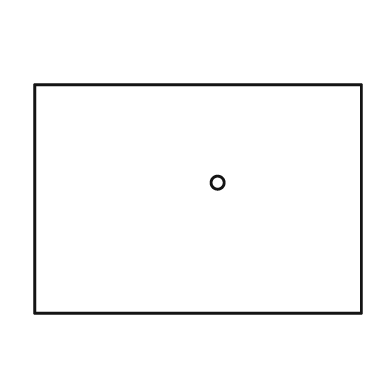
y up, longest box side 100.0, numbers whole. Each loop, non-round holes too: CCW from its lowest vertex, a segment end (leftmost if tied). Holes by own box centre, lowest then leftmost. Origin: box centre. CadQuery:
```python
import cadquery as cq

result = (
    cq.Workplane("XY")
    .moveTo(-50.0, -35.0)
    .lineTo(50.0, -35.0)
    .lineTo(50.0, 35.0)
    .lineTo(-50.0, 35.0)
    .close()
    .moveTo(6.0, 5.0)
    .circle(2.0)
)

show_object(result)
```